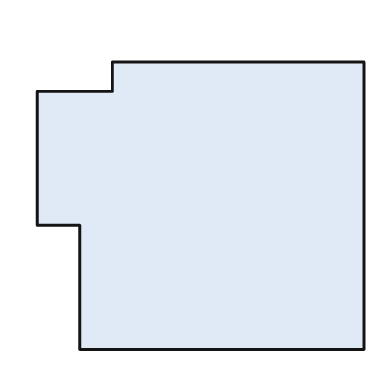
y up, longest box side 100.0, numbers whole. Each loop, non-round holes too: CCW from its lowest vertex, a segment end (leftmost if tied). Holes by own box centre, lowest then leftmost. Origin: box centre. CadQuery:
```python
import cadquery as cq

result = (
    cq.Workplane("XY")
    .moveTo(-37.0, -44.0)
    .lineTo(50.0, -44.0)
    .lineTo(50.0, 44.0)
    .lineTo(-27.0, 44.0)
    .lineTo(-27.0, 35.0)
    .lineTo(-50.0, 35.0)
    .lineTo(-50.0, -6.0)
    .lineTo(-37.0, -6.0)
    .close()
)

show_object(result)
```